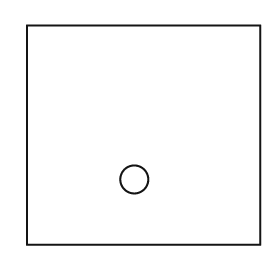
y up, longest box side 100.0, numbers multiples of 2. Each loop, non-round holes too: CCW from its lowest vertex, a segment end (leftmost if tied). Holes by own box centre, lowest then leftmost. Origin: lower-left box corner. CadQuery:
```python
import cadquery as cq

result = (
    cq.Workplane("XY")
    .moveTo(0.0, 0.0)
    .lineTo(100.0, 0.0)
    .lineTo(100.0, 94.0)
    .lineTo(0.0, 94.0)
    .close()
    .moveTo(46.0, 28.0)
    .circle(6.0)
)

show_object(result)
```